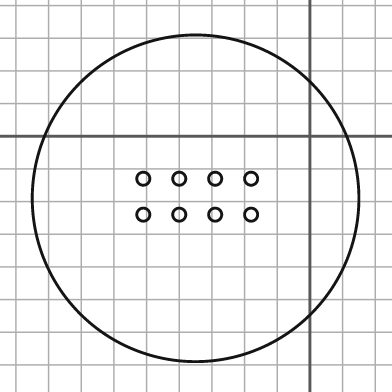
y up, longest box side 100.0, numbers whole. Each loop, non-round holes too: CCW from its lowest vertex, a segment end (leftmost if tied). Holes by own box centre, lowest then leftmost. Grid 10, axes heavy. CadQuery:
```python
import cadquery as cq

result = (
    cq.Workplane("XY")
    .moveTo(-35.0, -19.0)
    .circle(50.0)
    .moveTo(-51.0, -24.0)
    .circle(2.0)
    .moveTo(-40.0, -24.0)
    .circle(2.0)
    .moveTo(-29.0, -24.0)
    .circle(2.0)
    .moveTo(-18.0, -24.0)
    .circle(2.0)
    .moveTo(-51.0, -13.0)
    .circle(2.0)
    .moveTo(-40.0, -13.0)
    .circle(2.0)
    .moveTo(-29.0, -13.0)
    .circle(2.0)
    .moveTo(-18.0, -13.0)
    .circle(2.0)
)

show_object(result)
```